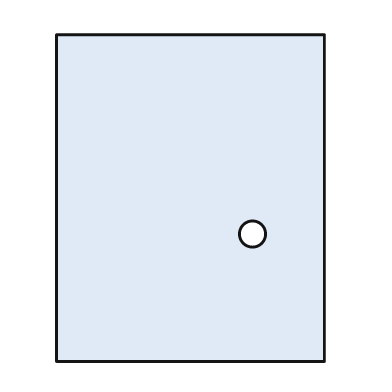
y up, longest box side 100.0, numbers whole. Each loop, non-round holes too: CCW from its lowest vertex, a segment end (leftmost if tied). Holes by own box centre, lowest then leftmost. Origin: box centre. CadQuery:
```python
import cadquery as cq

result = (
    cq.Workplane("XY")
    .moveTo(-41.0, -50.0)
    .lineTo(41.0, -50.0)
    .lineTo(41.0, 50.0)
    .lineTo(-41.0, 50.0)
    .close()
    .moveTo(19.0, -11.0)
    .circle(4.0)
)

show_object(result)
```